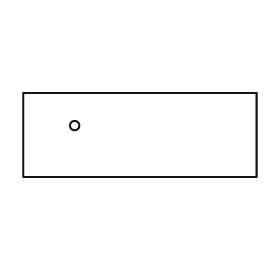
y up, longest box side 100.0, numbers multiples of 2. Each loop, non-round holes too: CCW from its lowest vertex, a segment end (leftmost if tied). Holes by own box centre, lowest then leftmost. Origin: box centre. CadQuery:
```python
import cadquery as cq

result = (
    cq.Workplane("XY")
    .moveTo(-50.0, -18.0)
    .lineTo(50.0, -18.0)
    .lineTo(50.0, 18.0)
    .lineTo(-50.0, 18.0)
    .close()
    .moveTo(-28.0, 4.0)
    .circle(2.0)
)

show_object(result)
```